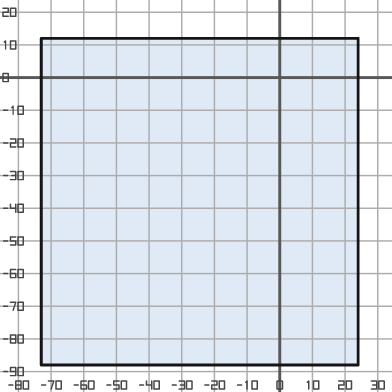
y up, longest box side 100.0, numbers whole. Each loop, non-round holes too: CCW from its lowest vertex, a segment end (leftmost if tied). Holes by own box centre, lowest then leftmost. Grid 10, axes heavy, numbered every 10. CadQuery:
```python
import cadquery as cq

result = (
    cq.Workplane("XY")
    .moveTo(-73.0, -88.0)
    .lineTo(24.0, -88.0)
    .lineTo(24.0, 12.0)
    .lineTo(-73.0, 12.0)
    .close()
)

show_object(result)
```